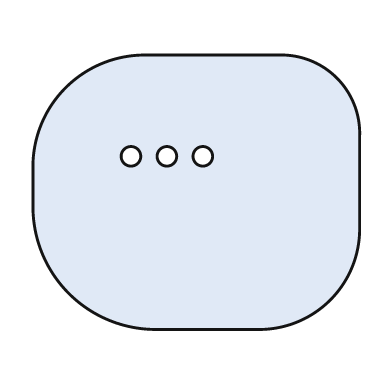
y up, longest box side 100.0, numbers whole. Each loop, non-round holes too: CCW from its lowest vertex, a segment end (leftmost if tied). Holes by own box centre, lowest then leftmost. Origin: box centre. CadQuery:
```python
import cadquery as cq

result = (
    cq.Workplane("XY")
    .moveTo(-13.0, -42.0)
    .lineTo(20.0, -42.0)
    .threePointArc((41.0, -33.0), (50.0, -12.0))
    .lineTo(50.0, 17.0)
    .threePointArc((43.0, 35.0), (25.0, 42.0))
    .lineTo(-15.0, 42.0)
    .threePointArc((-40.0, 32.0), (-50.0, 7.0))
    .lineTo(-50.0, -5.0)
    .threePointArc((-39.0, -31.0), (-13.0, -42.0))
    .close()
    .moveTo(-20.0, 11.0)
    .circle(3.0)
    .moveTo(-9.0, 11.0)
    .circle(3.0)
    .moveTo(2.0, 11.0)
    .circle(3.0)
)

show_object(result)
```